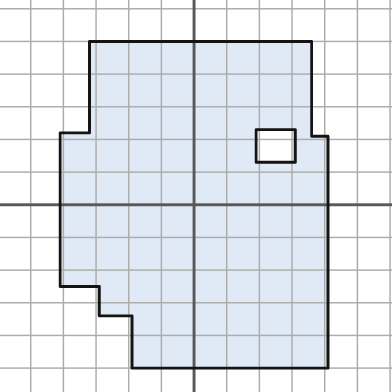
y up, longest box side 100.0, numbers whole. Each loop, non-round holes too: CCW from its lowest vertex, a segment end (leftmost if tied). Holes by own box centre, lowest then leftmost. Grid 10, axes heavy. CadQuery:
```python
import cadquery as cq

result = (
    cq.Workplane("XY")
    .moveTo(-19.0, -50.0)
    .lineTo(41.0, -50.0)
    .lineTo(41.0, 21.0)
    .lineTo(36.0, 21.0)
    .lineTo(36.0, 50.0)
    .lineTo(-32.0, 50.0)
    .lineTo(-32.0, 22.0)
    .lineTo(-41.0, 22.0)
    .lineTo(-41.0, -25.0)
    .lineTo(-29.0, -25.0)
    .lineTo(-29.0, -34.0)
    .lineTo(-19.0, -34.0)
    .close()
    .moveTo(19.0, 13.0)
    .lineTo(31.0, 13.0)
    .lineTo(31.0, 23.0)
    .lineTo(19.0, 23.0)
    .close()
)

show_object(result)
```